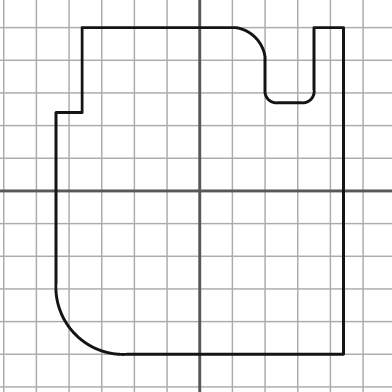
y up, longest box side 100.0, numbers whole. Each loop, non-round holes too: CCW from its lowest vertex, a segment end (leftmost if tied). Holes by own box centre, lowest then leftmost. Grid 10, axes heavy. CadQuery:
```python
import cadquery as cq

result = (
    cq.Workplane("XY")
    .moveTo(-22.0, -50.0)
    .lineTo(44.0, -50.0)
    .lineTo(44.0, 50.0)
    .lineTo(35.0, 50.0)
    .lineTo(35.0, 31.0)
    .threePointArc((34.0, 28.0), (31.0, 27.0))
    .lineTo(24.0, 27.0)
    .threePointArc((21.0, 28.0), (20.0, 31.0))
    .lineTo(20.0, 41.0)
    .threePointArc((17.0, 47.0), (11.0, 50.0))
    .lineTo(-36.0, 50.0)
    .lineTo(-36.0, 24.0)
    .lineTo(-44.0, 24.0)
    .lineTo(-44.0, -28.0)
    .threePointArc((-38.0, -44.0), (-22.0, -50.0))
    .close()
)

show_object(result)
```